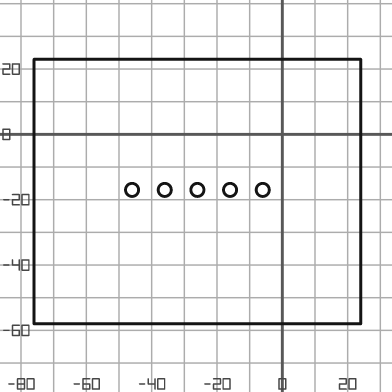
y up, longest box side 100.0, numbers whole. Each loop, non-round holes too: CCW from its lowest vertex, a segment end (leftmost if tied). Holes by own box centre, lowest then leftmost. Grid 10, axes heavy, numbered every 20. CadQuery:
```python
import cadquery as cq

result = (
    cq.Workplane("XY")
    .moveTo(-76.0, -58.0)
    .lineTo(24.0, -58.0)
    .lineTo(24.0, 23.0)
    .lineTo(-76.0, 23.0)
    .close()
    .moveTo(-46.0, -17.0)
    .circle(2.0)
    .moveTo(-36.0, -17.0)
    .circle(2.0)
    .moveTo(-26.0, -17.0)
    .circle(2.0)
    .moveTo(-16.0, -17.0)
    .circle(2.0)
    .moveTo(-6.0, -17.0)
    .circle(2.0)
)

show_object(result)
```